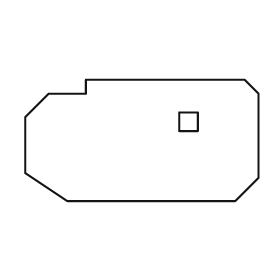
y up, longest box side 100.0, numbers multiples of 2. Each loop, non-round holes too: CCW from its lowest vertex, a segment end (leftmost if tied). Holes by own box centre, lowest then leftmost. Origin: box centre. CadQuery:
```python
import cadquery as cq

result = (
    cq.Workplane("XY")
    .moveTo(-32.0, -26.0)
    .lineTo(40.0, -26.0)
    .lineTo(50.0, -16.0)
    .lineTo(50.0, 20.0)
    .lineTo(44.0, 26.0)
    .lineTo(-24.0, 26.0)
    .lineTo(-24.0, 20.0)
    .lineTo(-40.0, 20.0)
    .lineTo(-50.0, 10.0)
    .lineTo(-50.0, -14.0)
    .close()
    .moveTo(16.0, 4.0)
    .lineTo(24.0, 4.0)
    .lineTo(24.0, 12.0)
    .lineTo(16.0, 12.0)
    .close()
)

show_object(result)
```